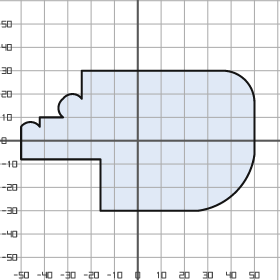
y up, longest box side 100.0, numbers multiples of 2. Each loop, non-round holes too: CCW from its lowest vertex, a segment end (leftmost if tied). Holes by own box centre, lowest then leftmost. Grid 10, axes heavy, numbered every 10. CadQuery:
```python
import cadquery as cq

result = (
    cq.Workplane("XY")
    .moveTo(-16.0, -30.0)
    .lineTo(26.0, -30.0)
    .threePointArc((42.0, -22.0), (50.0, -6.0))
    .lineTo(50.0, 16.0)
    .threePointArc((46.0, 26.0), (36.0, 30.0))
    .lineTo(-24.0, 30.0)
    .lineTo(-24.0, 18.0)
    .threePointArc((-28.0, 20.0), (-32.0, 18.0))
    .threePointArc((-34.0, 14.0), (-32.0, 10.0))
    .lineTo(-42.0, 10.0)
    .lineTo(-42.0, 6.0)
    .threePointArc((-46.0, 8.0), (-50.0, 6.0))
    .lineTo(-50.0, -8.0)
    .lineTo(-16.0, -8.0)
    .close()
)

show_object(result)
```